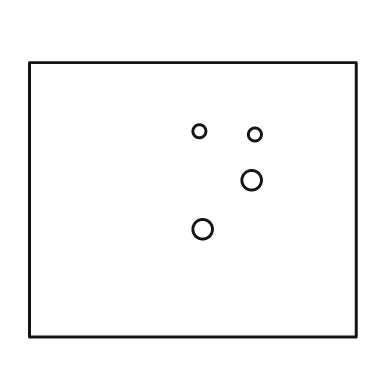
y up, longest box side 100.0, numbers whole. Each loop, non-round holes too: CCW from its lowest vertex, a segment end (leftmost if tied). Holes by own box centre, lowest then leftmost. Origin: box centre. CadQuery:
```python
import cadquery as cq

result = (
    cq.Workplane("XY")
    .moveTo(-50.0, -42.0)
    .lineTo(50.0, -42.0)
    .lineTo(50.0, 42.0)
    .lineTo(-50.0, 42.0)
    .close()
    .moveTo(3.0, -9.0)
    .circle(3.0)
    .moveTo(18.0, 6.0)
    .circle(3.0)
    .moveTo(19.0, 20.0)
    .circle(2.0)
    .moveTo(2.0, 21.0)
    .circle(2.0)
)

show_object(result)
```